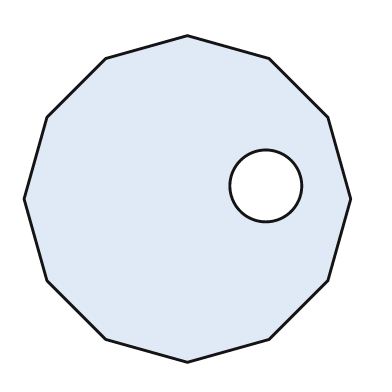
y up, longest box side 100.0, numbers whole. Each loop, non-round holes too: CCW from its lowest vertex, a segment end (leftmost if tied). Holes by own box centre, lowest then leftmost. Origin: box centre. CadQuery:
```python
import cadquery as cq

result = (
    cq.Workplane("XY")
    .moveTo(0.0, -50.0)
    .lineTo(25.0, -43.0)
    .lineTo(43.0, -25.0)
    .lineTo(50.0, 0.0)
    .lineTo(43.0, 25.0)
    .lineTo(25.0, 43.0)
    .lineTo(0.0, 50.0)
    .lineTo(-25.0, 43.0)
    .lineTo(-43.0, 25.0)
    .lineTo(-50.0, 0.0)
    .lineTo(-43.0, -25.0)
    .lineTo(-25.0, -43.0)
    .close()
    .moveTo(24.0, 4.0)
    .circle(11.0)
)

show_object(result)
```